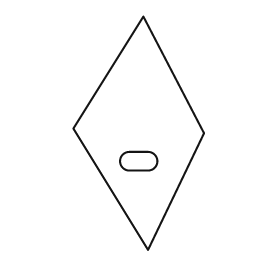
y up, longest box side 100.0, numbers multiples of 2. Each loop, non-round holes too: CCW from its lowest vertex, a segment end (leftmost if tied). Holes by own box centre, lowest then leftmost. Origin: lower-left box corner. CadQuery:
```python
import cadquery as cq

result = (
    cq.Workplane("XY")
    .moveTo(32.0, 0.0)
    .lineTo(56.0, 50.0)
    .lineTo(30.0, 100.0)
    .lineTo(0.0, 52.0)
    .close()
    .moveTo(24.0, 34.0)
    .lineTo(32.0, 34.0)
    .threePointArc((36.0, 38.0), (32.0, 42.0))
    .lineTo(24.0, 42.0)
    .threePointArc((20.0, 38.0), (24.0, 34.0))
    .close()
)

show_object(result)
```